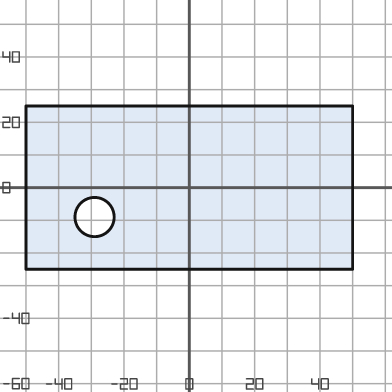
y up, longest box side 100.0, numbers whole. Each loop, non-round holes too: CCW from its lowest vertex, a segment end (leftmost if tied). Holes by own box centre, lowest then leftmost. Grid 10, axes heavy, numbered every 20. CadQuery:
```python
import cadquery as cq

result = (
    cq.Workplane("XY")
    .moveTo(-50.0, -25.0)
    .lineTo(50.0, -25.0)
    .lineTo(50.0, 25.0)
    .lineTo(-50.0, 25.0)
    .close()
    .moveTo(-29.0, -9.0)
    .circle(6.0)
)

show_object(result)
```